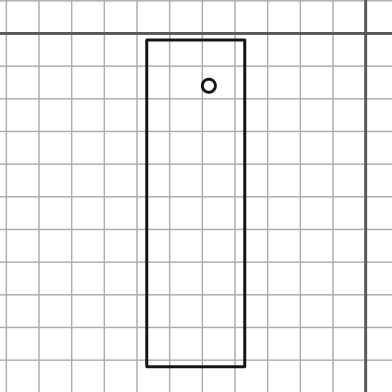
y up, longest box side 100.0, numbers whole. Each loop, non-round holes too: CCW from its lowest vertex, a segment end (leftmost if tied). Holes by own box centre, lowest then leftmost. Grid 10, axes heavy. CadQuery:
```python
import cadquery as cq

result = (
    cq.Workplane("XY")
    .moveTo(-67.0, -102.0)
    .lineTo(-37.0, -102.0)
    .lineTo(-37.0, -2.0)
    .lineTo(-67.0, -2.0)
    .close()
    .moveTo(-48.0, -16.0)
    .circle(2.0)
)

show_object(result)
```